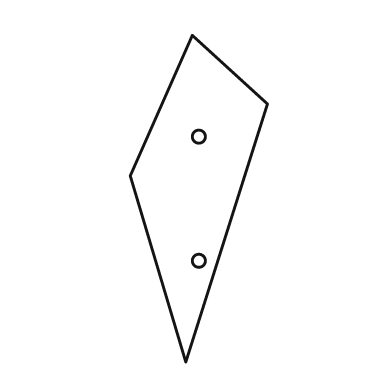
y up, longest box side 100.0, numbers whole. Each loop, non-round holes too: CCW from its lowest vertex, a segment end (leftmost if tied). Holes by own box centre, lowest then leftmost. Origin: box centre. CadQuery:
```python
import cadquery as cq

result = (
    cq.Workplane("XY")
    .moveTo(-4.0, -50.0)
    .lineTo(21.0, 29.0)
    .lineTo(-2.0, 50.0)
    .lineTo(-21.0, 7.0)
    .close()
    .moveTo(0.0, -19.0)
    .circle(2.0)
    .moveTo(0.0, 19.0)
    .circle(2.0)
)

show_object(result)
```